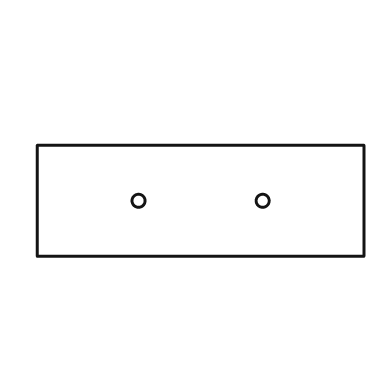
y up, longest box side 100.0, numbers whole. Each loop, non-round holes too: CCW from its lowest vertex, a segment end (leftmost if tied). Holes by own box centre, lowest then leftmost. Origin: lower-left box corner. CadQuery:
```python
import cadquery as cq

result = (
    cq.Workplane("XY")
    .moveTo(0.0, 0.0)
    .lineTo(100.0, 0.0)
    .lineTo(100.0, 34.0)
    .lineTo(0.0, 34.0)
    .close()
    .moveTo(31.0, 17.0)
    .circle(2.0)
    .moveTo(69.0, 17.0)
    .circle(2.0)
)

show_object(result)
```